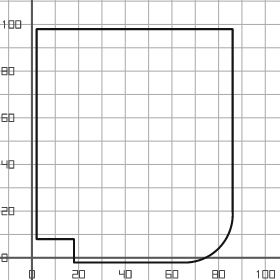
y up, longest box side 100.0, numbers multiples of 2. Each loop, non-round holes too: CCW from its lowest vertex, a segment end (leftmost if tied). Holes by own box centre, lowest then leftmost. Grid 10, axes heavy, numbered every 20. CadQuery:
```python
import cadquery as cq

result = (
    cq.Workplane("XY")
    .moveTo(18.0, -2.0)
    .lineTo(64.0, -2.0)
    .threePointArc((80.0, 4.0), (86.0, 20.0))
    .lineTo(86.0, 98.0)
    .lineTo(2.0, 98.0)
    .lineTo(2.0, 8.0)
    .lineTo(18.0, 8.0)
    .close()
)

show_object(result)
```